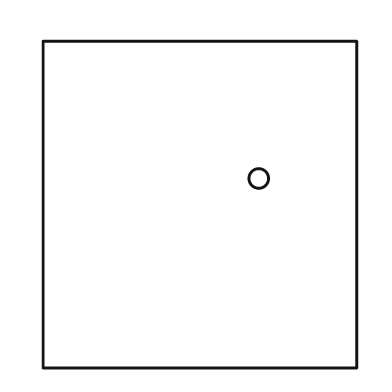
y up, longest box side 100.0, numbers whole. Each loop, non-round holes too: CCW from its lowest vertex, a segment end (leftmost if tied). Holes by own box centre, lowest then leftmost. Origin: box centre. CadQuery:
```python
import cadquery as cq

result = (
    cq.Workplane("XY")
    .moveTo(-48.0, -50.0)
    .lineTo(48.0, -50.0)
    .lineTo(48.0, 50.0)
    .lineTo(-48.0, 50.0)
    .close()
    .moveTo(18.0, 8.0)
    .circle(3.0)
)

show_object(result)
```